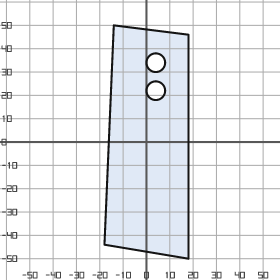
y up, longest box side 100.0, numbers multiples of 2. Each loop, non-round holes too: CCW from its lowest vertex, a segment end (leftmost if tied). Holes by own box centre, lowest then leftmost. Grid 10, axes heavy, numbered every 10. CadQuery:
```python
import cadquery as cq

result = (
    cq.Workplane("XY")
    .moveTo(18.0, -50.0)
    .lineTo(18.0, 46.0)
    .lineTo(-14.0, 50.0)
    .lineTo(-18.0, -44.0)
    .close()
    .moveTo(4.0, 22.0)
    .circle(4.0)
    .moveTo(4.0, 34.0)
    .circle(4.0)
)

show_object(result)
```